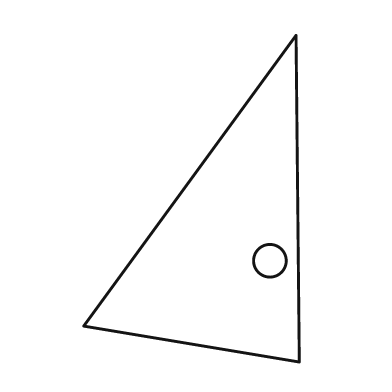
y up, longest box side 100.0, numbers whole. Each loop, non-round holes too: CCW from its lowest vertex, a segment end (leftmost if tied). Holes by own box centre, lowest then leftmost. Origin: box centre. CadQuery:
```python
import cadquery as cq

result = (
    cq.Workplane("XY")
    .moveTo(33.0, -50.0)
    .lineTo(32.0, 50.0)
    .lineTo(-33.0, -39.0)
    .close()
    .moveTo(24.0, -19.0)
    .circle(5.0)
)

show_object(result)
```